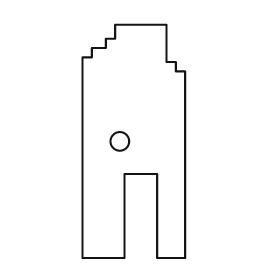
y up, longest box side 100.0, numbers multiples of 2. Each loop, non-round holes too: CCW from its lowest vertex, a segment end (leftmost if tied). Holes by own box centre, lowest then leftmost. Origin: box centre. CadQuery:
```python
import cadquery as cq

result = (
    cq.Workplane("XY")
    .moveTo(-22.0, -50.0)
    .lineTo(-4.0, -50.0)
    .lineTo(-4.0, -14.0)
    .lineTo(10.0, -14.0)
    .lineTo(10.0, -50.0)
    .lineTo(22.0, -50.0)
    .lineTo(22.0, 30.0)
    .lineTo(18.0, 30.0)
    .lineTo(18.0, 34.0)
    .lineTo(14.0, 34.0)
    .lineTo(14.0, 50.0)
    .lineTo(-8.0, 50.0)
    .lineTo(-8.0, 44.0)
    .lineTo(-12.0, 44.0)
    .lineTo(-12.0, 40.0)
    .lineTo(-18.0, 40.0)
    .lineTo(-18.0, 36.0)
    .lineTo(-22.0, 36.0)
    .close()
    .moveTo(-6.0, 0.0)
    .circle(4.0)
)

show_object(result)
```